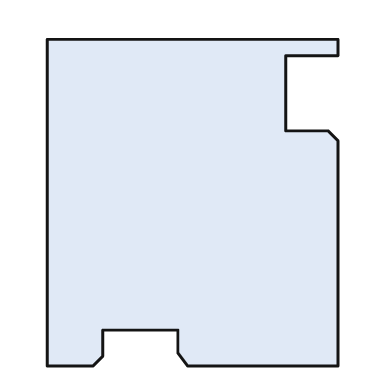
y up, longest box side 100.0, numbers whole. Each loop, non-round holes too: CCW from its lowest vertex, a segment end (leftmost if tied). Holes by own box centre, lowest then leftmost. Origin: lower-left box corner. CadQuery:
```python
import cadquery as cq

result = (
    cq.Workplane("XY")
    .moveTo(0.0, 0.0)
    .lineTo(14.0, 0.0)
    .lineTo(17.0, 3.0)
    .lineTo(17.0, 11.0)
    .lineTo(40.0, 11.0)
    .lineTo(40.0, 4.0)
    .lineTo(43.0, 0.0)
    .lineTo(89.0, 0.0)
    .lineTo(89.0, 69.0)
    .lineTo(86.0, 72.0)
    .lineTo(73.0, 72.0)
    .lineTo(73.0, 95.0)
    .lineTo(89.0, 95.0)
    .lineTo(89.0, 100.0)
    .lineTo(0.0, 100.0)
    .close()
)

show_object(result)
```